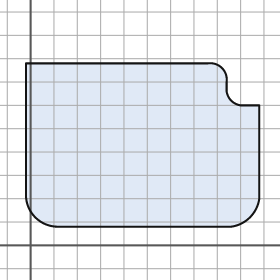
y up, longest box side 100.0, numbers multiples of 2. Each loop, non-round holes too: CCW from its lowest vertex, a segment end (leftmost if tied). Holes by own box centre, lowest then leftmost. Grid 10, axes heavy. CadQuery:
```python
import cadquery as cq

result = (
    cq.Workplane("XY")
    .moveTo(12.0, 8.0)
    .lineTo(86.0, 8.0)
    .threePointArc((94.0, 12.0), (98.0, 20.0))
    .lineTo(98.0, 60.0)
    .lineTo(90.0, 60.0)
    .threePointArc((86.0, 62.0), (84.0, 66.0))
    .lineTo(84.0, 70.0)
    .threePointArc((82.0, 76.0), (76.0, 78.0))
    .lineTo(-2.0, 78.0)
    .lineTo(-2.0, 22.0)
    .threePointArc((2.0, 12.0), (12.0, 8.0))
    .close()
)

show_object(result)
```